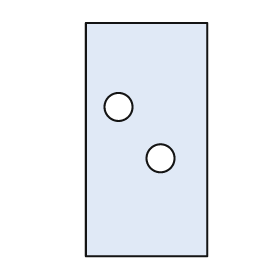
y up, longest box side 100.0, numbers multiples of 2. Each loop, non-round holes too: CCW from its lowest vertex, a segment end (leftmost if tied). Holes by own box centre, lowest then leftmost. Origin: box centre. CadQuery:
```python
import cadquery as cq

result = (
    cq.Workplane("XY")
    .moveTo(-26.0, -50.0)
    .lineTo(26.0, -50.0)
    .lineTo(26.0, 50.0)
    .lineTo(-26.0, 50.0)
    .close()
    .moveTo(6.0, -8.0)
    .circle(6.0)
    .moveTo(-12.0, 14.0)
    .circle(6.0)
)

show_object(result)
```